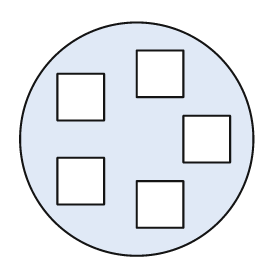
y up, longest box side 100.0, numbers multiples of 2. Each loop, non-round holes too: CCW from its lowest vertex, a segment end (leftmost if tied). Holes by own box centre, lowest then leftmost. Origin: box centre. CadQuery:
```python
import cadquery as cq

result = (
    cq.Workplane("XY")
    .moveTo(0.0, 0.0)
    .circle(50.0)
    .moveTo(0.0, -38.0)
    .lineTo(20.0, -38.0)
    .lineTo(20.0, -18.0)
    .lineTo(0.0, -18.0)
    .close()
    .moveTo(-34.0, -28.0)
    .lineTo(-14.0, -28.0)
    .lineTo(-14.0, -8.0)
    .lineTo(-34.0, -8.0)
    .close()
    .moveTo(20.0, -10.0)
    .lineTo(40.0, -10.0)
    .lineTo(40.0, 10.0)
    .lineTo(20.0, 10.0)
    .close()
    .moveTo(-34.0, 8.0)
    .lineTo(-14.0, 8.0)
    .lineTo(-14.0, 28.0)
    .lineTo(-34.0, 28.0)
    .close()
    .moveTo(0.0, 18.0)
    .lineTo(20.0, 18.0)
    .lineTo(20.0, 38.0)
    .lineTo(0.0, 38.0)
    .close()
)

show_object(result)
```